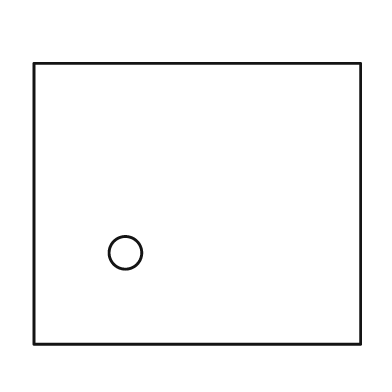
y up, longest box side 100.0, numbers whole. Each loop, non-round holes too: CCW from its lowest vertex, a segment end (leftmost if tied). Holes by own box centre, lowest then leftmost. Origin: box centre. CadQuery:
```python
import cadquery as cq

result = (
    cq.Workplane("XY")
    .moveTo(-50.0, -43.0)
    .lineTo(50.0, -43.0)
    .lineTo(50.0, 43.0)
    .lineTo(-50.0, 43.0)
    .close()
    .moveTo(-22.0, -15.0)
    .circle(5.0)
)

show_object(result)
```